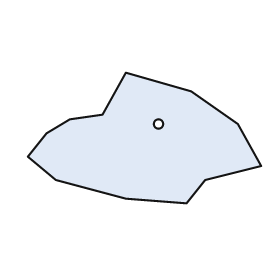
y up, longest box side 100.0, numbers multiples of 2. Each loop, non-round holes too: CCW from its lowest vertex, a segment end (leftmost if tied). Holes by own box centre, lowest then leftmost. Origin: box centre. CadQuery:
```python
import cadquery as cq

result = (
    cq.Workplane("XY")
    .moveTo(18.0, -28.0)
    .lineTo(26.0, -18.0)
    .lineTo(50.0, -12.0)
    .lineTo(40.0, 6.0)
    .lineTo(20.0, 20.0)
    .lineTo(-8.0, 28.0)
    .lineTo(-18.0, 10.0)
    .lineTo(-32.0, 8.0)
    .lineTo(-42.0, 2.0)
    .lineTo(-50.0, -8.0)
    .lineTo(-38.0, -18.0)
    .lineTo(-8.0, -26.0)
    .close()
    .moveTo(6.0, 6.0)
    .circle(2.0)
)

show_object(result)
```